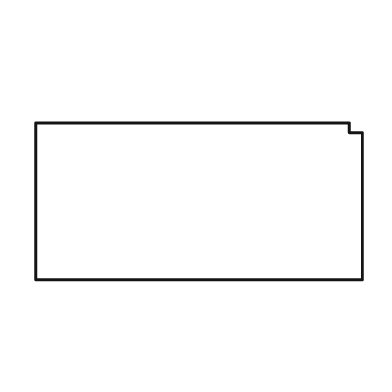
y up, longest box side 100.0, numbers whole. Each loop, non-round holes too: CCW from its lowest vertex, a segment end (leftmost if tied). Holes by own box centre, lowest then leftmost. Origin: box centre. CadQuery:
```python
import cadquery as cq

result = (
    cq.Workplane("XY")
    .moveTo(-50.0, -24.0)
    .lineTo(50.0, -24.0)
    .lineTo(50.0, 21.0)
    .lineTo(46.0, 21.0)
    .lineTo(46.0, 24.0)
    .lineTo(-50.0, 24.0)
    .close()
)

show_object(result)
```